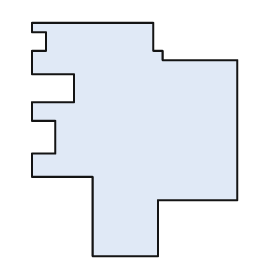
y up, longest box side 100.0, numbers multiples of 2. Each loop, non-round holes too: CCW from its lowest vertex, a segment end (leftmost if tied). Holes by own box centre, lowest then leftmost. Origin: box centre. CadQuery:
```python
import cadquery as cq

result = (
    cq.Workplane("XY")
    .moveTo(-18.0, -50.0)
    .lineTo(10.0, -50.0)
    .lineTo(10.0, -26.0)
    .lineTo(44.0, -26.0)
    .lineTo(44.0, 34.0)
    .lineTo(12.0, 34.0)
    .lineTo(12.0, 38.0)
    .lineTo(8.0, 38.0)
    .lineTo(8.0, 50.0)
    .lineTo(-44.0, 50.0)
    .lineTo(-44.0, 46.0)
    .lineTo(-38.0, 46.0)
    .lineTo(-38.0, 38.0)
    .lineTo(-44.0, 38.0)
    .lineTo(-44.0, 28.0)
    .lineTo(-26.0, 28.0)
    .lineTo(-26.0, 16.0)
    .lineTo(-44.0, 16.0)
    .lineTo(-44.0, 8.0)
    .lineTo(-34.0, 8.0)
    .lineTo(-34.0, -6.0)
    .lineTo(-44.0, -6.0)
    .lineTo(-44.0, -16.0)
    .lineTo(-18.0, -16.0)
    .close()
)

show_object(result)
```